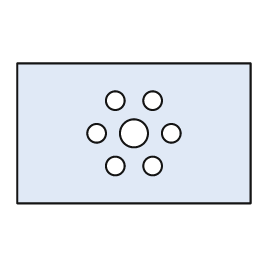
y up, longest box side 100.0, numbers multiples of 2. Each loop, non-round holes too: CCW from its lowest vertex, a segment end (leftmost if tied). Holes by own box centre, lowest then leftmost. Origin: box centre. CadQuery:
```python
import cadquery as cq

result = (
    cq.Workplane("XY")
    .moveTo(-50.0, -30.0)
    .lineTo(50.0, -30.0)
    .lineTo(50.0, 30.0)
    .lineTo(-50.0, 30.0)
    .close()
    .moveTo(-8.0, -14.0)
    .circle(4.0)
    .moveTo(8.0, -14.0)
    .circle(4.0)
    .moveTo(-16.0, 0.0)
    .circle(4.0)
    .moveTo(0.0, 0.0)
    .circle(6.0)
    .moveTo(16.0, 0.0)
    .circle(4.0)
    .moveTo(-8.0, 14.0)
    .circle(4.0)
    .moveTo(8.0, 14.0)
    .circle(4.0)
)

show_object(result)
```